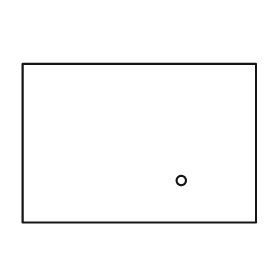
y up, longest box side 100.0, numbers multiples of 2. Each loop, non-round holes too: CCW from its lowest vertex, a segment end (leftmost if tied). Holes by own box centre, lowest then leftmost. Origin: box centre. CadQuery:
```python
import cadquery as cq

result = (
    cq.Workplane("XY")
    .moveTo(-50.0, -34.0)
    .lineTo(50.0, -34.0)
    .lineTo(50.0, 34.0)
    .lineTo(-50.0, 34.0)
    .close()
    .moveTo(18.0, -16.0)
    .circle(2.0)
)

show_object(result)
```